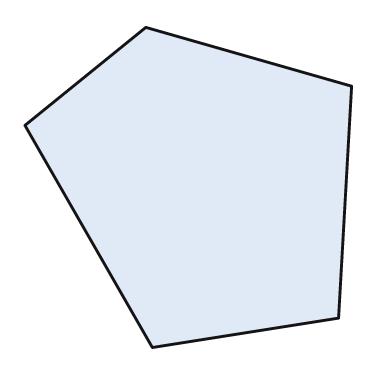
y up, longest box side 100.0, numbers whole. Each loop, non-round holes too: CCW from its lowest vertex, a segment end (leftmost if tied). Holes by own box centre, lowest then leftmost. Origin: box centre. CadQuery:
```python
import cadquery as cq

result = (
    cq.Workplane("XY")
    .moveTo(-11.0, -49.0)
    .lineTo(46.0, -40.0)
    .lineTo(50.0, 31.0)
    .lineTo(-13.0, 49.0)
    .lineTo(-50.0, 19.0)
    .close()
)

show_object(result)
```